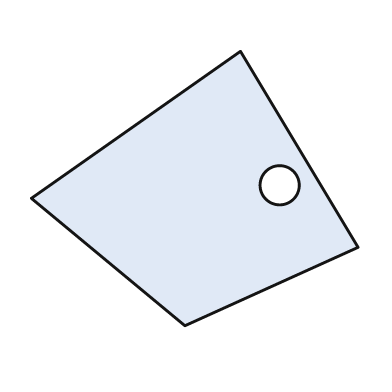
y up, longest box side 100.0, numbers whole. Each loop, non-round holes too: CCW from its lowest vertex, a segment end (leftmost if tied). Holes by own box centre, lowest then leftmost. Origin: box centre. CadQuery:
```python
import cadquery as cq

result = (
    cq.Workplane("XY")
    .moveTo(-3.0, -42.0)
    .lineTo(50.0, -18.0)
    .lineTo(14.0, 42.0)
    .lineTo(-50.0, -3.0)
    .close()
    .moveTo(26.0, 1.0)
    .circle(6.0)
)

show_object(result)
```